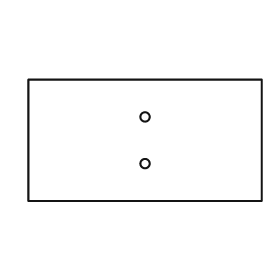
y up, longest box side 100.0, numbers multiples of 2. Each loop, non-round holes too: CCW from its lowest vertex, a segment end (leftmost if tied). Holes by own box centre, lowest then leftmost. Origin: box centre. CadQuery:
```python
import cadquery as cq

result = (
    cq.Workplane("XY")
    .moveTo(-50.0, -26.0)
    .lineTo(50.0, -26.0)
    .lineTo(50.0, 26.0)
    .lineTo(-50.0, 26.0)
    .close()
    .moveTo(0.0, -10.0)
    .circle(2.0)
    .moveTo(0.0, 10.0)
    .circle(2.0)
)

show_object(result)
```